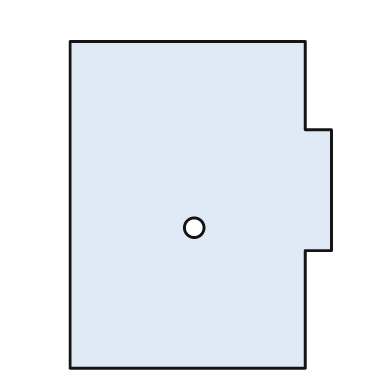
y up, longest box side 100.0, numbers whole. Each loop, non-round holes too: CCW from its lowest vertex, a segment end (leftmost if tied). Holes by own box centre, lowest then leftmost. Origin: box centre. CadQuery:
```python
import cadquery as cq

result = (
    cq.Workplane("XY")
    .moveTo(-40.0, -50.0)
    .lineTo(32.0, -50.0)
    .lineTo(32.0, -14.0)
    .lineTo(40.0, -14.0)
    .lineTo(40.0, 23.0)
    .lineTo(32.0, 23.0)
    .lineTo(32.0, 50.0)
    .lineTo(-40.0, 50.0)
    .close()
    .moveTo(-2.0, -7.0)
    .circle(3.0)
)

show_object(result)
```